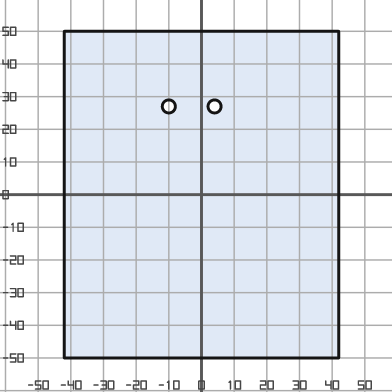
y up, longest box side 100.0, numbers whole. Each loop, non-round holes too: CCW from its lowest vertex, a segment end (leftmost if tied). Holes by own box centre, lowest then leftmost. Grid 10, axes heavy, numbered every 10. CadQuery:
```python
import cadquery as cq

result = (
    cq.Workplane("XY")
    .moveTo(-42.0, -50.0)
    .lineTo(42.0, -50.0)
    .lineTo(42.0, 50.0)
    .lineTo(-42.0, 50.0)
    .close()
    .moveTo(-10.0, 27.0)
    .circle(2.0)
    .moveTo(4.0, 27.0)
    .circle(2.0)
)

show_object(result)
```